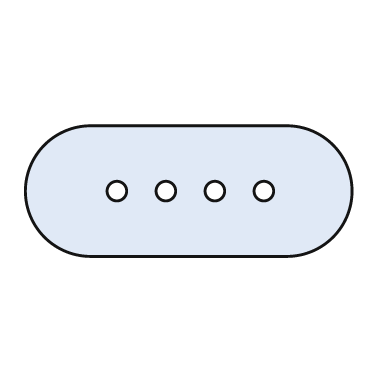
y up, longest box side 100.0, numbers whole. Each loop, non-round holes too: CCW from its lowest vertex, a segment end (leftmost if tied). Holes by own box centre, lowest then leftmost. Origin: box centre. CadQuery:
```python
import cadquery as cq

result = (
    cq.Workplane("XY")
    .moveTo(-30.0, -20.0)
    .lineTo(30.0, -20.0)
    .threePointArc((50.0, 0.0), (30.0, 20.0))
    .lineTo(-30.0, 20.0)
    .threePointArc((-50.0, 0.0), (-30.0, -20.0))
    .close()
    .moveTo(-22.0, 0.0)
    .circle(3.0)
    .moveTo(-7.0, 0.0)
    .circle(3.0)
    .moveTo(8.0, 0.0)
    .circle(3.0)
    .moveTo(23.0, 0.0)
    .circle(3.0)
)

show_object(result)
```